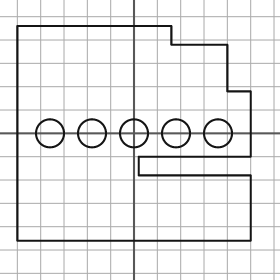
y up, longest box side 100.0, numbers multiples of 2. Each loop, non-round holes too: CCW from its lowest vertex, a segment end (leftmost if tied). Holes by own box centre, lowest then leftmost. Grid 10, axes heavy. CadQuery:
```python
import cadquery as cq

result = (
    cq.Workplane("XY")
    .moveTo(-50.0, -46.0)
    .lineTo(50.0, -46.0)
    .lineTo(50.0, -18.0)
    .lineTo(2.0, -18.0)
    .lineTo(2.0, -10.0)
    .lineTo(50.0, -10.0)
    .lineTo(50.0, 18.0)
    .lineTo(40.0, 18.0)
    .lineTo(40.0, 38.0)
    .lineTo(16.0, 38.0)
    .lineTo(16.0, 46.0)
    .lineTo(-50.0, 46.0)
    .close()
    .moveTo(-36.0, 0.0)
    .circle(6.0)
    .moveTo(-18.0, 0.0)
    .circle(6.0)
    .moveTo(0.0, 0.0)
    .circle(6.0)
    .moveTo(18.0, 0.0)
    .circle(6.0)
    .moveTo(36.0, 0.0)
    .circle(6.0)
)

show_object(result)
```